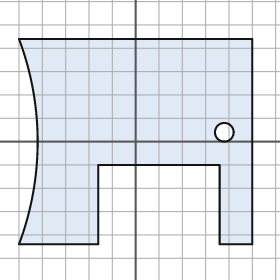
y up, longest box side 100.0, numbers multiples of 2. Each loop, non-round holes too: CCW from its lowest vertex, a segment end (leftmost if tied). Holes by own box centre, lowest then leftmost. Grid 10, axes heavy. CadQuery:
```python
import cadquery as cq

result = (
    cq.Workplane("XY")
    .moveTo(-50.0, -44.0)
    .lineTo(-16.0, -44.0)
    .lineTo(-16.0, -10.0)
    .lineTo(36.0, -10.0)
    .lineTo(36.0, -44.0)
    .lineTo(50.0, -44.0)
    .lineTo(50.0, 44.0)
    .lineTo(-50.0, 44.0)
    .threePointArc((-42.0, 0.0), (-50.0, -44.0))
    .close()
    .moveTo(38.0, 4.0)
    .circle(4.0)
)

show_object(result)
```